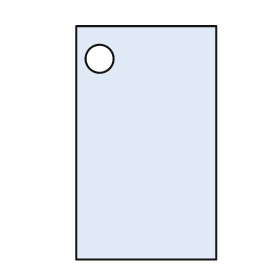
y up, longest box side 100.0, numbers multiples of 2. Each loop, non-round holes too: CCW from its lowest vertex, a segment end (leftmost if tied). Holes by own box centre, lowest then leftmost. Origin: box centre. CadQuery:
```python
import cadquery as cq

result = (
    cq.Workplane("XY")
    .moveTo(-30.0, -50.0)
    .lineTo(30.0, -50.0)
    .lineTo(30.0, 50.0)
    .lineTo(-30.0, 50.0)
    .close()
    .moveTo(-20.0, 36.0)
    .circle(6.0)
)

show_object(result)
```